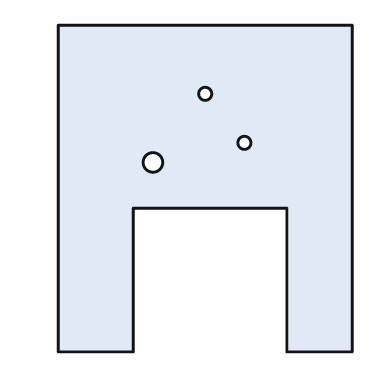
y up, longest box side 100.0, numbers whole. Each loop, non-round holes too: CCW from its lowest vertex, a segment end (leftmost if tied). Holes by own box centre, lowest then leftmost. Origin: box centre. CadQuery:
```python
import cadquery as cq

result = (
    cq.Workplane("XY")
    .moveTo(-45.0, -50.0)
    .lineTo(-22.0, -50.0)
    .lineTo(-22.0, -6.0)
    .lineTo(25.0, -6.0)
    .lineTo(25.0, -50.0)
    .lineTo(45.0, -50.0)
    .lineTo(45.0, 50.0)
    .lineTo(-45.0, 50.0)
    .close()
    .moveTo(-16.0, 8.0)
    .circle(3.0)
    .moveTo(12.0, 14.0)
    .circle(2.0)
    .moveTo(0.0, 29.0)
    .circle(2.0)
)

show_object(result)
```